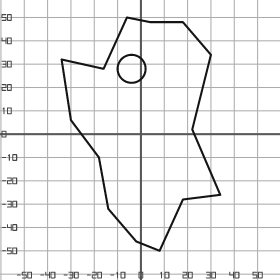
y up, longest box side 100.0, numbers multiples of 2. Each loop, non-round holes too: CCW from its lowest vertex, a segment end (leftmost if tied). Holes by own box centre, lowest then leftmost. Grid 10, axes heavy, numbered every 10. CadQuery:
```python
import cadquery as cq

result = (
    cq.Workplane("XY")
    .moveTo(8.0, -50.0)
    .lineTo(18.0, -28.0)
    .lineTo(34.0, -26.0)
    .lineTo(22.0, 2.0)
    .lineTo(30.0, 34.0)
    .lineTo(18.0, 48.0)
    .lineTo(4.0, 48.0)
    .lineTo(-6.0, 50.0)
    .lineTo(-16.0, 28.0)
    .lineTo(-34.0, 32.0)
    .lineTo(-30.0, 6.0)
    .lineTo(-18.0, -10.0)
    .lineTo(-14.0, -32.0)
    .lineTo(-2.0, -46.0)
    .close()
    .moveTo(-4.0, 28.0)
    .circle(6.0)
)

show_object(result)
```